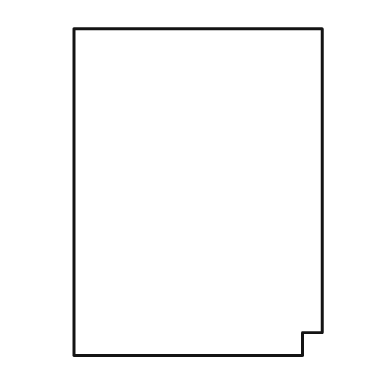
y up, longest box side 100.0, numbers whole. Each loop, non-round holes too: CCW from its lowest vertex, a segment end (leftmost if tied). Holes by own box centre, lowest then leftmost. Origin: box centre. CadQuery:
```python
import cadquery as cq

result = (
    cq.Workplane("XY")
    .moveTo(-38.0, -50.0)
    .lineTo(32.0, -50.0)
    .lineTo(32.0, -43.0)
    .lineTo(38.0, -43.0)
    .lineTo(38.0, 50.0)
    .lineTo(-38.0, 50.0)
    .close()
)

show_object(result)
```